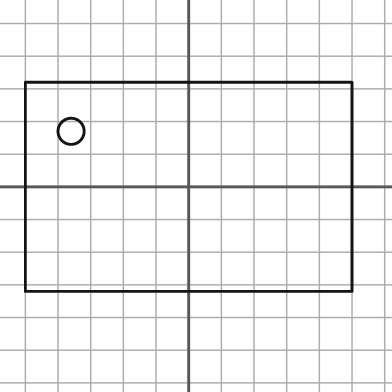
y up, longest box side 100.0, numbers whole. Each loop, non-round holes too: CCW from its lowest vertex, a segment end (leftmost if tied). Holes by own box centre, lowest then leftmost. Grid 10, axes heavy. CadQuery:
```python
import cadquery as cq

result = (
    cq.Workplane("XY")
    .moveTo(-50.0, -32.0)
    .lineTo(50.0, -32.0)
    .lineTo(50.0, 32.0)
    .lineTo(-50.0, 32.0)
    .close()
    .moveTo(-36.0, 17.0)
    .circle(4.0)
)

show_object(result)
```